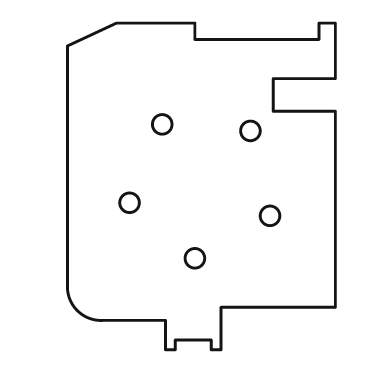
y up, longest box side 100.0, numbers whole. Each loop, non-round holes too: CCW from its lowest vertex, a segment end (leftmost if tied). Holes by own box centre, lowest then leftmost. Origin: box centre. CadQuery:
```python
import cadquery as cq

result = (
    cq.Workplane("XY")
    .moveTo(-11.0, -50.0)
    .lineTo(-8.0, -50.0)
    .lineTo(-8.0, -47.0)
    .lineTo(3.0, -47.0)
    .lineTo(3.0, -50.0)
    .lineTo(6.0, -50.0)
    .lineTo(6.0, -37.0)
    .lineTo(41.0, -37.0)
    .lineTo(41.0, 23.0)
    .lineTo(22.0, 23.0)
    .lineTo(22.0, 33.0)
    .lineTo(41.0, 33.0)
    .lineTo(41.0, 50.0)
    .lineTo(36.0, 50.0)
    .lineTo(36.0, 45.0)
    .lineTo(-2.0, 45.0)
    .lineTo(-2.0, 50.0)
    .lineTo(-26.0, 50.0)
    .lineTo(-41.0, 43.0)
    .lineTo(-41.0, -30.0)
    .threePointArc((-38.0, -38.0), (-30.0, -41.0))
    .lineTo(-11.0, -41.0)
    .close()
    .moveTo(-2.0, -22.0)
    .circle(3.0)
    .moveTo(21.0, -9.0)
    .circle(3.0)
    .moveTo(-22.0, -5.0)
    .circle(3.0)
    .moveTo(15.0, 17.0)
    .circle(3.0)
    .moveTo(-12.0, 19.0)
    .circle(3.0)
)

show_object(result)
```